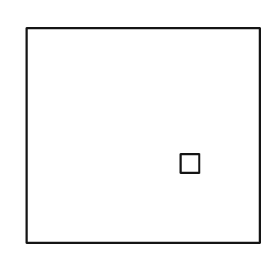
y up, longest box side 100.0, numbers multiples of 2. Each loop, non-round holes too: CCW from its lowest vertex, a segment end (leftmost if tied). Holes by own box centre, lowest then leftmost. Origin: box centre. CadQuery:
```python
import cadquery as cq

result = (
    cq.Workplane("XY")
    .moveTo(-50.0, -46.0)
    .lineTo(50.0, -46.0)
    .lineTo(50.0, 46.0)
    .lineTo(-50.0, 46.0)
    .close()
    .moveTo(16.0, -16.0)
    .lineTo(24.0, -16.0)
    .lineTo(24.0, -8.0)
    .lineTo(16.0, -8.0)
    .close()
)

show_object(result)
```